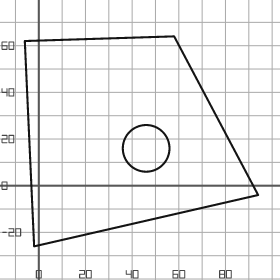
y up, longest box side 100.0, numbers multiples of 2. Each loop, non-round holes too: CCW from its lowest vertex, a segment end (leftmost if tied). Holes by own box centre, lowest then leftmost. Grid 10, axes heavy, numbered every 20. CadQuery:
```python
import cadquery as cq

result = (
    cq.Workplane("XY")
    .moveTo(-2.0, -26.0)
    .lineTo(94.0, -4.0)
    .lineTo(58.0, 64.0)
    .lineTo(-6.0, 62.0)
    .close()
    .moveTo(46.0, 16.0)
    .circle(10.0)
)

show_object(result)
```